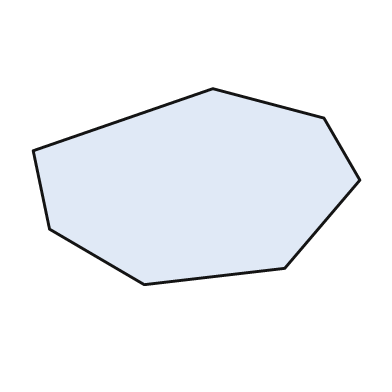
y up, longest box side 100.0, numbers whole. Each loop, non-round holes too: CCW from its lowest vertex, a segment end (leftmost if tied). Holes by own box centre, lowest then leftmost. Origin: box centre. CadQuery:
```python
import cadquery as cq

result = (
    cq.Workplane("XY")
    .moveTo(-16.0, -30.0)
    .lineTo(27.0, -25.0)
    .lineTo(50.0, 2.0)
    .lineTo(39.0, 21.0)
    .lineTo(5.0, 30.0)
    .lineTo(-50.0, 11.0)
    .lineTo(-45.0, -13.0)
    .close()
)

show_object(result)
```